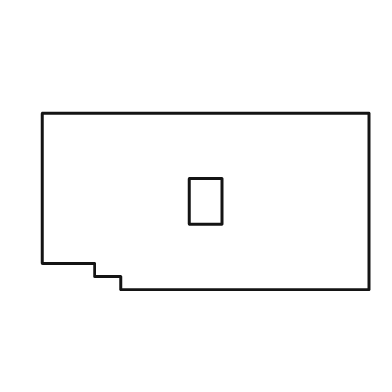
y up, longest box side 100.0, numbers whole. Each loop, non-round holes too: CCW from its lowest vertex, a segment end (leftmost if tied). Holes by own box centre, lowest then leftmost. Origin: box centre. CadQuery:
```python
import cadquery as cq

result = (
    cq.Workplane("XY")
    .moveTo(-26.0, -27.0)
    .lineTo(50.0, -27.0)
    .lineTo(50.0, 27.0)
    .lineTo(-50.0, 27.0)
    .lineTo(-50.0, -19.0)
    .lineTo(-34.0, -19.0)
    .lineTo(-34.0, -23.0)
    .lineTo(-26.0, -23.0)
    .close()
    .moveTo(-5.0, -7.0)
    .lineTo(5.0, -7.0)
    .lineTo(5.0, 7.0)
    .lineTo(-5.0, 7.0)
    .close()
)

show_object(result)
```